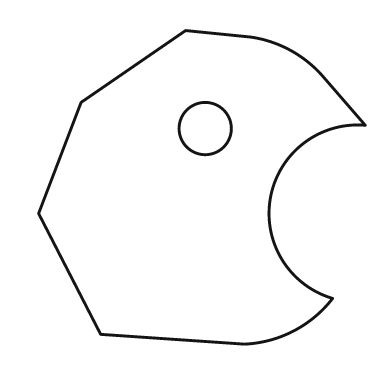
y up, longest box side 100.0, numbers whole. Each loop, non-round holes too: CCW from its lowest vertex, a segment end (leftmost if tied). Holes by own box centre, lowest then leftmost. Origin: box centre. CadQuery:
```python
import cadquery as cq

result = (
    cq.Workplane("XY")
    .moveTo(13.0, -48.0)
    .threePointArc((28.0, -44.0), (40.0, -34.0))
    .threePointArc((21.0, -3.0), (50.0, 19.0))
    .lineTo(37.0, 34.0)
    .threePointArc((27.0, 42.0), (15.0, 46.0))
    .lineTo(-5.0, 48.0)
    .lineTo(-37.0, 26.0)
    .lineTo(-50.0, -8.0)
    .lineTo(-31.0, -45.0)
    .close()
    .moveTo(1.0, 18.0)
    .circle(8.0)
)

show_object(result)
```